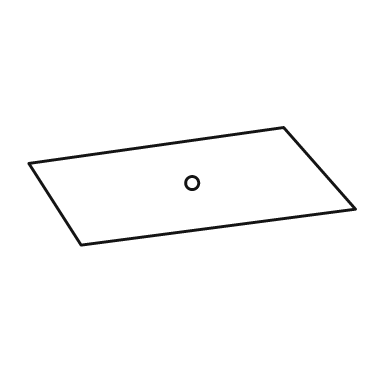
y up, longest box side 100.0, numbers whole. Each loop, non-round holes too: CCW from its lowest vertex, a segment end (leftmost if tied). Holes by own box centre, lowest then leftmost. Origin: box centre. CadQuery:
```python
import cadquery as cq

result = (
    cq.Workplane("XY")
    .moveTo(-34.0, -18.0)
    .lineTo(50.0, -7.0)
    .lineTo(28.0, 18.0)
    .lineTo(-50.0, 7.0)
    .close()
    .moveTo(0.0, 1.0)
    .circle(2.0)
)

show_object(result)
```